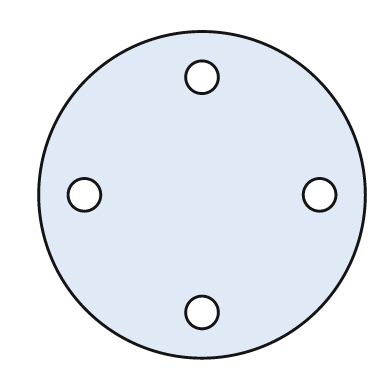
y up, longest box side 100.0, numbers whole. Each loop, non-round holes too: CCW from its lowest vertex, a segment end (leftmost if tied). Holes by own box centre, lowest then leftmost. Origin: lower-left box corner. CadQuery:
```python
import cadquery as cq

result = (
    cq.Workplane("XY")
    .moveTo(50.0, 50.0)
    .circle(50.0)
    .moveTo(50.0, 14.0)
    .circle(5.0)
    .moveTo(14.0, 50.0)
    .circle(5.0)
    .moveTo(86.0, 50.0)
    .circle(5.0)
    .moveTo(50.0, 86.0)
    .circle(5.0)
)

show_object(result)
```